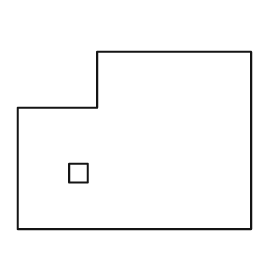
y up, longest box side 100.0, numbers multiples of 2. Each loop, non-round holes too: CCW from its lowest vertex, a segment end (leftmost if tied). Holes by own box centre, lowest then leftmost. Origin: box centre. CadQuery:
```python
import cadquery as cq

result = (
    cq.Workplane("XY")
    .moveTo(-50.0, -38.0)
    .lineTo(50.0, -38.0)
    .lineTo(50.0, 38.0)
    .lineTo(-16.0, 38.0)
    .lineTo(-16.0, 14.0)
    .lineTo(-50.0, 14.0)
    .close()
    .moveTo(-28.0, -18.0)
    .lineTo(-20.0, -18.0)
    .lineTo(-20.0, -10.0)
    .lineTo(-28.0, -10.0)
    .close()
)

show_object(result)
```